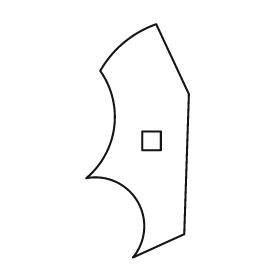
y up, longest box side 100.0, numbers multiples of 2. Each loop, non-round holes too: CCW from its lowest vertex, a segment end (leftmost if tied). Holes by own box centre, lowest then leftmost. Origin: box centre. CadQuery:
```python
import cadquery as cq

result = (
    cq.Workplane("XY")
    .moveTo(-2.0, -50.0)
    .lineTo(20.0, -40.0)
    .lineTo(22.0, 20.0)
    .lineTo(8.0, 50.0)
    .threePointArc((-6.0, 42.0), (-16.0, 30.0))
    .threePointArc((-10.0, 6.0), (-22.0, -16.0))
    .threePointArc((0.0, -26.0), (-2.0, -50.0))
    .close()
    .moveTo(2.0, -4.0)
    .lineTo(10.0, -4.0)
    .lineTo(10.0, 4.0)
    .lineTo(2.0, 4.0)
    .close()
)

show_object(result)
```